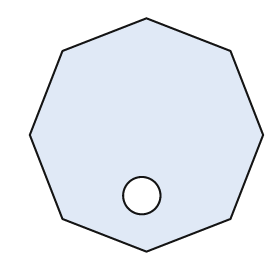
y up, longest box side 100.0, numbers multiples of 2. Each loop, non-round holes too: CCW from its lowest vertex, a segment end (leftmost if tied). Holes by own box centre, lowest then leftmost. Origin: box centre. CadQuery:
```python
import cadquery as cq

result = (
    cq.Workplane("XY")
    .moveTo(0.0, -50.0)
    .lineTo(36.0, -36.0)
    .lineTo(50.0, 0.0)
    .lineTo(36.0, 36.0)
    .lineTo(0.0, 50.0)
    .lineTo(-36.0, 36.0)
    .lineTo(-50.0, 0.0)
    .lineTo(-36.0, -36.0)
    .close()
    .moveTo(-2.0, -26.0)
    .circle(8.0)
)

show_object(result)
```